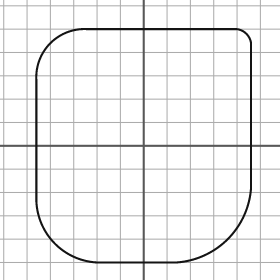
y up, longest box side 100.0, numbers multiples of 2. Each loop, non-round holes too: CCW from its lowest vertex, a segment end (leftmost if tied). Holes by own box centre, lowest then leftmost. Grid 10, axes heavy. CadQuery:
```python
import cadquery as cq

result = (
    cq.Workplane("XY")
    .moveTo(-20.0, -50.0)
    .lineTo(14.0, -50.0)
    .threePointArc((36.0, -40.0), (46.0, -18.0))
    .lineTo(46.0, 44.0)
    .threePointArc((44.0, 48.0), (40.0, 50.0))
    .lineTo(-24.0, 50.0)
    .threePointArc((-40.0, 44.0), (-46.0, 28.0))
    .lineTo(-46.0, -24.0)
    .threePointArc((-38.0, -42.0), (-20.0, -50.0))
    .close()
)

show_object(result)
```